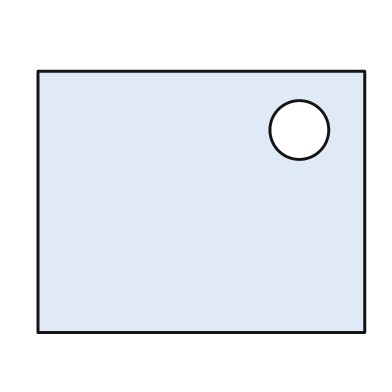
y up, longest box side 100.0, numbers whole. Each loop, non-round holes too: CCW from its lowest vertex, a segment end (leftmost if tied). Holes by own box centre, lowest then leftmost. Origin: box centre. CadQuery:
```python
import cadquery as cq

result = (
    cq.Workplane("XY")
    .moveTo(-50.0, -40.0)
    .lineTo(50.0, -40.0)
    .lineTo(50.0, 40.0)
    .lineTo(-50.0, 40.0)
    .close()
    .moveTo(30.0, 22.0)
    .circle(9.0)
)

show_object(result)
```